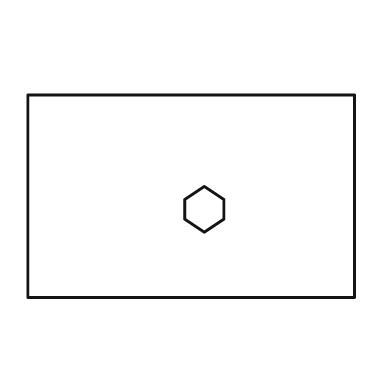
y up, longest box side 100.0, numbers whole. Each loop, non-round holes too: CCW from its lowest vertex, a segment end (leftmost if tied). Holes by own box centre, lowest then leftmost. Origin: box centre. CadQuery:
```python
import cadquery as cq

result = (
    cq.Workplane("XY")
    .moveTo(-50.0, -31.0)
    .lineTo(50.0, -31.0)
    .lineTo(50.0, 31.0)
    .lineTo(-50.0, 31.0)
    .close()
    .moveTo(4.0, -11.0)
    .lineTo(10.0, -7.0)
    .lineTo(10.0, -1.0)
    .lineTo(4.0, 3.0)
    .lineTo(-2.0, -1.0)
    .lineTo(-2.0, -7.0)
    .close()
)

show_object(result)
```